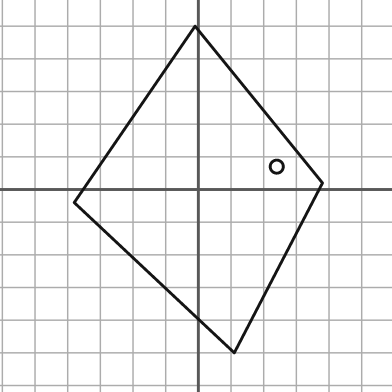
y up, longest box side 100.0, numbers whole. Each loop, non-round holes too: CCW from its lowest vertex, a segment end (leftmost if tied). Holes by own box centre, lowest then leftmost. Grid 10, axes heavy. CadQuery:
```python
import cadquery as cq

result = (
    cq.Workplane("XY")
    .moveTo(11.0, -50.0)
    .lineTo(38.0, 2.0)
    .lineTo(-1.0, 50.0)
    .lineTo(-38.0, -4.0)
    .close()
    .moveTo(24.0, 7.0)
    .circle(2.0)
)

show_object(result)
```